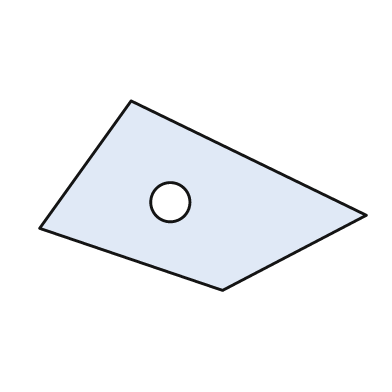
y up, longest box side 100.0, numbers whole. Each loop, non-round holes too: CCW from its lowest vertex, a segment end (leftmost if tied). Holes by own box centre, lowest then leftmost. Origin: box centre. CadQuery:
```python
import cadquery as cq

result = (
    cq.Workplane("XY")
    .moveTo(6.0, -29.0)
    .lineTo(50.0, -6.0)
    .lineTo(-22.0, 29.0)
    .lineTo(-50.0, -10.0)
    .close()
    .moveTo(-10.0, -2.0)
    .circle(6.0)
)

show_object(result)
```